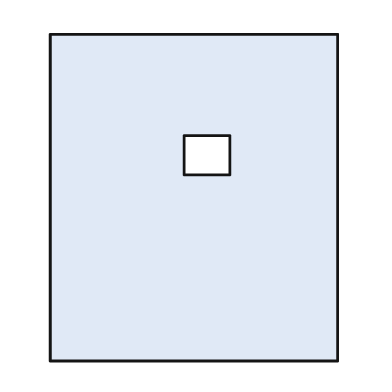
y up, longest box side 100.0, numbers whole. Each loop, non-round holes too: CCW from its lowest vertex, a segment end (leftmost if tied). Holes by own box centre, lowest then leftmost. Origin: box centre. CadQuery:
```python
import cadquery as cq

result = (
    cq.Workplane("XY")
    .moveTo(-44.0, -50.0)
    .lineTo(44.0, -50.0)
    .lineTo(44.0, 50.0)
    .lineTo(-44.0, 50.0)
    .close()
    .moveTo(-3.0, 7.0)
    .lineTo(11.0, 7.0)
    .lineTo(11.0, 19.0)
    .lineTo(-3.0, 19.0)
    .close()
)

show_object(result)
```